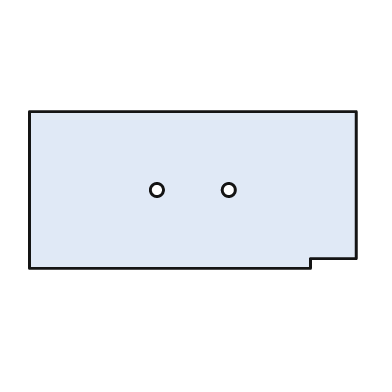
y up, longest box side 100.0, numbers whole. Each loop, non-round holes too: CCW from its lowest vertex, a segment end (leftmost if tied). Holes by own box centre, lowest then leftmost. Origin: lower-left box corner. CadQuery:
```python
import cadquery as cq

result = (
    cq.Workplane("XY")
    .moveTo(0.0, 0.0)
    .lineTo(86.0, 0.0)
    .lineTo(86.0, 3.0)
    .lineTo(100.0, 3.0)
    .lineTo(100.0, 48.0)
    .lineTo(0.0, 48.0)
    .close()
    .moveTo(39.0, 24.0)
    .circle(2.0)
    .moveTo(61.0, 24.0)
    .circle(2.0)
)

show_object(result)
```